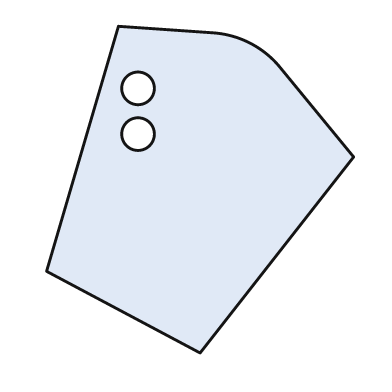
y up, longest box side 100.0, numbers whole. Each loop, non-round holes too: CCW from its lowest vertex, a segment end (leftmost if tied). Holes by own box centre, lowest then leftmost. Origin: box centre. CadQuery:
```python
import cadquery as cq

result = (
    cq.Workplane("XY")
    .moveTo(0.0, -50.0)
    .lineTo(47.0, 10.0)
    .lineTo(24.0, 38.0)
    .threePointArc((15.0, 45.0), (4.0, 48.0))
    .lineTo(-25.0, 50.0)
    .lineTo(-47.0, -25.0)
    .close()
    .moveTo(-19.0, 17.0)
    .circle(5.0)
    .moveTo(-19.0, 31.0)
    .circle(5.0)
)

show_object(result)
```